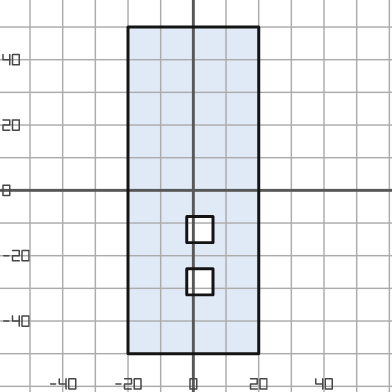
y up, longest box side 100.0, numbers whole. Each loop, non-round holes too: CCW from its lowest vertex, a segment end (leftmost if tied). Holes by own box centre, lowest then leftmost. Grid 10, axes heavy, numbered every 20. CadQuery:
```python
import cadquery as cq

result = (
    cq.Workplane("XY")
    .moveTo(-20.0, -50.0)
    .lineTo(20.0, -50.0)
    .lineTo(20.0, 50.0)
    .lineTo(-20.0, 50.0)
    .close()
    .moveTo(-2.0, -32.0)
    .lineTo(6.0, -32.0)
    .lineTo(6.0, -24.0)
    .lineTo(-2.0, -24.0)
    .close()
    .moveTo(-2.0, -16.0)
    .lineTo(6.0, -16.0)
    .lineTo(6.0, -8.0)
    .lineTo(-2.0, -8.0)
    .close()
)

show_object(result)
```